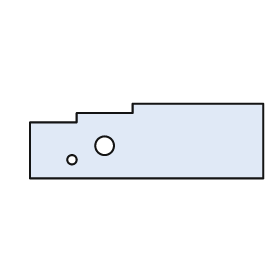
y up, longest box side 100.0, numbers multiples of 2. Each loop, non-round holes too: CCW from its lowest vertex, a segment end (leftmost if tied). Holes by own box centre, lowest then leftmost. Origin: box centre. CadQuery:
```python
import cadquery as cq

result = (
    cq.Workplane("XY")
    .moveTo(-50.0, -16.0)
    .lineTo(50.0, -16.0)
    .lineTo(50.0, 16.0)
    .lineTo(-6.0, 16.0)
    .lineTo(-6.0, 12.0)
    .lineTo(-30.0, 12.0)
    .lineTo(-30.0, 8.0)
    .lineTo(-50.0, 8.0)
    .close()
    .moveTo(-32.0, -8.0)
    .circle(2.0)
    .moveTo(-18.0, -2.0)
    .circle(4.0)
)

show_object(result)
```